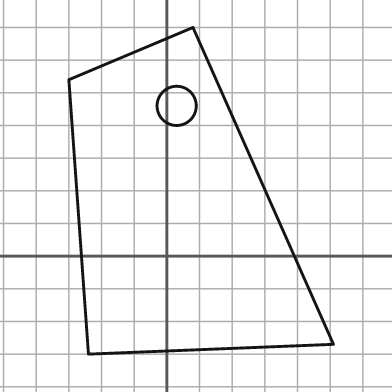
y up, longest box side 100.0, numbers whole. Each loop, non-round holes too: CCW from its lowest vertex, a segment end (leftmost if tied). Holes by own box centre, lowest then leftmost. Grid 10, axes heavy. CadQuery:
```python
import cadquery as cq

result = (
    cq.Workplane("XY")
    .moveTo(-24.0, -30.0)
    .lineTo(51.0, -27.0)
    .lineTo(8.0, 70.0)
    .lineTo(-30.0, 54.0)
    .close()
    .moveTo(3.0, 46.0)
    .circle(6.0)
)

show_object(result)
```